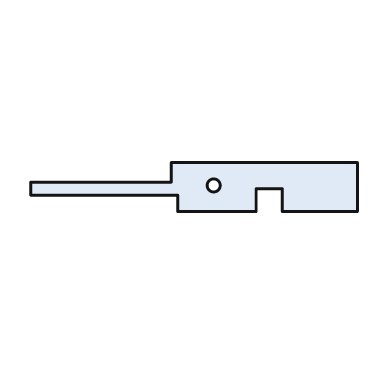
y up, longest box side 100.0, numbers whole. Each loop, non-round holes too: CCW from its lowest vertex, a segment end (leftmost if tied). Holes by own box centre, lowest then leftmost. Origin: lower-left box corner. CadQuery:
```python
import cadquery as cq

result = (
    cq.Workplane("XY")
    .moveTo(45.0, 0.0)
    .lineTo(69.0, 0.0)
    .lineTo(69.0, 7.0)
    .lineTo(77.0, 7.0)
    .lineTo(77.0, 0.0)
    .lineTo(100.0, 0.0)
    .lineTo(100.0, 15.0)
    .lineTo(43.0, 15.0)
    .lineTo(43.0, 9.0)
    .lineTo(0.0, 9.0)
    .lineTo(0.0, 5.0)
    .lineTo(45.0, 5.0)
    .close()
    .moveTo(56.0, 8.0)
    .circle(2.0)
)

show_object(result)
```